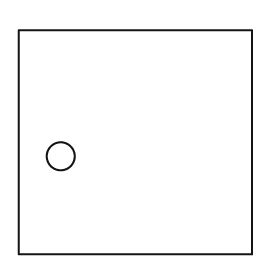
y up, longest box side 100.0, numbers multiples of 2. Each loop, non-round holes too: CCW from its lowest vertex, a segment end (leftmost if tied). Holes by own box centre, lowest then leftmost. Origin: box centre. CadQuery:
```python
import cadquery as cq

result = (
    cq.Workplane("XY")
    .moveTo(-50.0, -48.0)
    .lineTo(50.0, -48.0)
    .lineTo(50.0, 48.0)
    .lineTo(-50.0, 48.0)
    .close()
    .moveTo(-32.0, -6.0)
    .circle(6.0)
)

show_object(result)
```